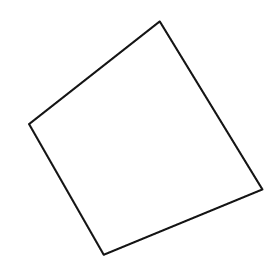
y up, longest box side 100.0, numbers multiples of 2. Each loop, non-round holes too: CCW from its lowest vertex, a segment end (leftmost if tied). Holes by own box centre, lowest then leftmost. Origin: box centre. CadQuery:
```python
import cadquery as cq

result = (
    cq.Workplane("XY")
    .moveTo(-18.0, -50.0)
    .lineTo(50.0, -22.0)
    .lineTo(6.0, 50.0)
    .lineTo(-50.0, 6.0)
    .close()
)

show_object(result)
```